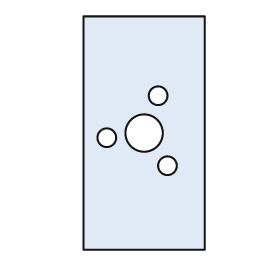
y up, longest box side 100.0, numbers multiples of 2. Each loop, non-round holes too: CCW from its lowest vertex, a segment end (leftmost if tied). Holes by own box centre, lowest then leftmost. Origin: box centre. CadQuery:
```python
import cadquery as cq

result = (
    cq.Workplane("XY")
    .moveTo(-26.0, -50.0)
    .lineTo(26.0, -50.0)
    .lineTo(26.0, 50.0)
    .lineTo(-26.0, 50.0)
    .close()
    .moveTo(10.0, -14.0)
    .circle(4.0)
    .moveTo(-16.0, -2.0)
    .circle(4.0)
    .moveTo(0.0, 0.0)
    .circle(8.0)
    .moveTo(6.0, 16.0)
    .circle(4.0)
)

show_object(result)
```